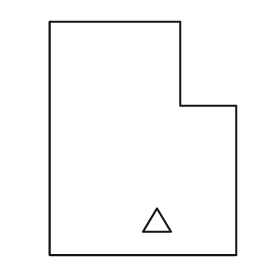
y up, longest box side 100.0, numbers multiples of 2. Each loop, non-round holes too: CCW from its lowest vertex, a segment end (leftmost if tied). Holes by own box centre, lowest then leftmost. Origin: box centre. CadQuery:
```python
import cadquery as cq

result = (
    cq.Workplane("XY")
    .moveTo(-40.0, -50.0)
    .lineTo(40.0, -50.0)
    .lineTo(40.0, 14.0)
    .lineTo(16.0, 14.0)
    .lineTo(16.0, 50.0)
    .lineTo(-40.0, 50.0)
    .close()
    .moveTo(0.0, -40.0)
    .lineTo(12.0, -40.0)
    .lineTo(6.0, -30.0)
    .close()
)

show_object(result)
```